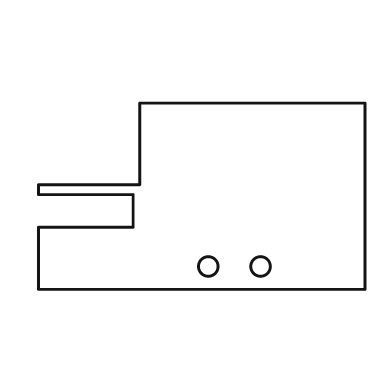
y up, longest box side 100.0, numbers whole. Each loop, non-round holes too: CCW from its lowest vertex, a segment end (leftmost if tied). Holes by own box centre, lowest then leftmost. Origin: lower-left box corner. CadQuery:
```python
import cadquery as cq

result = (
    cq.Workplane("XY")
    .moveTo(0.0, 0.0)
    .lineTo(100.0, 0.0)
    .lineTo(100.0, 57.0)
    .lineTo(31.0, 57.0)
    .lineTo(31.0, 32.0)
    .lineTo(0.0, 32.0)
    .lineTo(0.0, 29.0)
    .lineTo(29.0, 29.0)
    .lineTo(29.0, 19.0)
    .lineTo(0.0, 19.0)
    .close()
    .moveTo(52.0, 7.0)
    .circle(3.0)
    .moveTo(68.0, 7.0)
    .circle(3.0)
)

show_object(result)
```